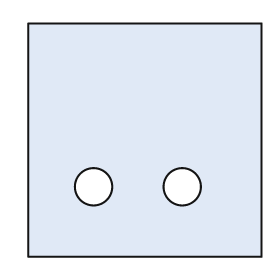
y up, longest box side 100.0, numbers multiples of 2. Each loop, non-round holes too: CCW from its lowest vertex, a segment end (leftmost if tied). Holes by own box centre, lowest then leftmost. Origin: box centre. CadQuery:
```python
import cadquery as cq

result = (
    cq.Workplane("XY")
    .moveTo(-50.0, -50.0)
    .lineTo(50.0, -50.0)
    .lineTo(50.0, 50.0)
    .lineTo(-50.0, 50.0)
    .close()
    .moveTo(-22.0, -20.0)
    .circle(8.0)
    .moveTo(16.0, -20.0)
    .circle(8.0)
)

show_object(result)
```